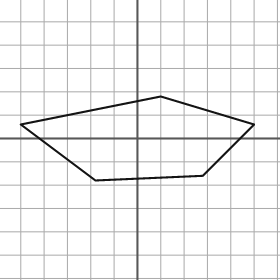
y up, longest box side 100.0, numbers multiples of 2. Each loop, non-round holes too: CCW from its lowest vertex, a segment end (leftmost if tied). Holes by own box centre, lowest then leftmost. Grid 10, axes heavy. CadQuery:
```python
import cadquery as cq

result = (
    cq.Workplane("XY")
    .moveTo(-18.0, -18.0)
    .lineTo(28.0, -16.0)
    .lineTo(50.0, 6.0)
    .lineTo(10.0, 18.0)
    .lineTo(-50.0, 6.0)
    .close()
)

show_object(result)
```